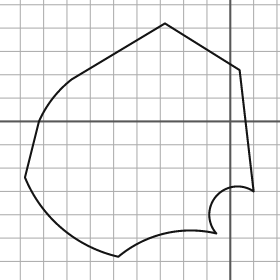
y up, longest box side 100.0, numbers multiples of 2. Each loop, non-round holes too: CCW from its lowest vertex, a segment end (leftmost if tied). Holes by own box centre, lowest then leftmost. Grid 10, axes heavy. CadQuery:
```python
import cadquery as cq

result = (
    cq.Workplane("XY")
    .moveTo(-48.0, -58.0)
    .threePointArc((-28.0, -48.0), (-6.0, -48.0))
    .threePointArc((-6.0, -32.0), (10.0, -30.0))
    .lineTo(4.0, 22.0)
    .lineTo(-28.0, 42.0)
    .lineTo(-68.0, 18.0)
    .threePointArc((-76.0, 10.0), (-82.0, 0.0))
    .lineTo(-88.0, -24.0)
    .threePointArc((-72.0, -46.0), (-48.0, -58.0))
    .close()
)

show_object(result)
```